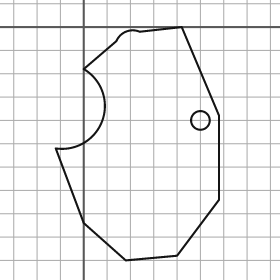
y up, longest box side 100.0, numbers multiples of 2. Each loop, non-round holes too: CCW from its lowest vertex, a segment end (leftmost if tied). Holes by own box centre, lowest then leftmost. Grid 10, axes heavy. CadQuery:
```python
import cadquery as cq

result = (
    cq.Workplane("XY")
    .moveTo(18.0, -100.0)
    .lineTo(40.0, -98.0)
    .lineTo(58.0, -74.0)
    .lineTo(58.0, -38.0)
    .lineTo(42.0, 0.0)
    .lineTo(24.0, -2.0)
    .threePointArc((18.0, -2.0), (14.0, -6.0))
    .lineTo(0.0, -18.0)
    .threePointArc((8.0, -40.0), (-12.0, -52.0))
    .lineTo(0.0, -84.0)
    .close()
    .moveTo(50.0, -40.0)
    .circle(4.0)
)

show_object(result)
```